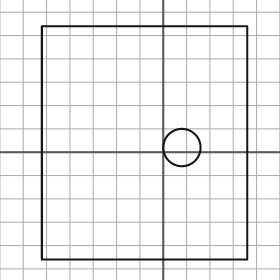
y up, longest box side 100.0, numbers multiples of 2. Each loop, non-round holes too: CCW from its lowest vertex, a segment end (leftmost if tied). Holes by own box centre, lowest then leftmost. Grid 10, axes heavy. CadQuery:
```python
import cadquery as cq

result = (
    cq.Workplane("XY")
    .moveTo(-52.0, -46.0)
    .lineTo(36.0, -46.0)
    .lineTo(36.0, 54.0)
    .lineTo(-52.0, 54.0)
    .close()
    .moveTo(8.0, 2.0)
    .circle(8.0)
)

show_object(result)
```